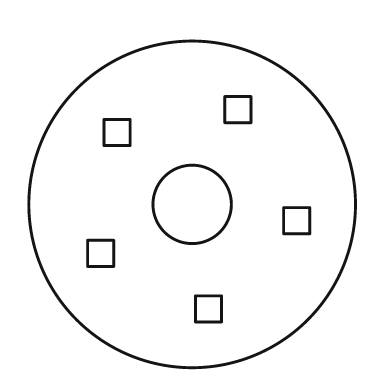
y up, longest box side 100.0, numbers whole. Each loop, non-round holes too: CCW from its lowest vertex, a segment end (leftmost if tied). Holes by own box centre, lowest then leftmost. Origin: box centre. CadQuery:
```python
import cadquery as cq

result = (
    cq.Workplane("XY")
    .moveTo(0.0, 0.0)
    .circle(50.0)
    .moveTo(1.0, -36.0)
    .lineTo(9.0, -36.0)
    .lineTo(9.0, -28.0)
    .lineTo(1.0, -28.0)
    .close()
    .moveTo(-32.0, -19.0)
    .lineTo(-24.0, -19.0)
    .lineTo(-24.0, -11.0)
    .lineTo(-32.0, -11.0)
    .close()
    .moveTo(28.0, -9.0)
    .lineTo(36.0, -9.0)
    .lineTo(36.0, -1.0)
    .lineTo(28.0, -1.0)
    .close()
    .moveTo(0.0, 0.0)
    .circle(12.0)
    .moveTo(-27.0, 18.0)
    .lineTo(-19.0, 18.0)
    .lineTo(-19.0, 26.0)
    .lineTo(-27.0, 26.0)
    .close()
    .moveTo(10.0, 25.0)
    .lineTo(18.0, 25.0)
    .lineTo(18.0, 33.0)
    .lineTo(10.0, 33.0)
    .close()
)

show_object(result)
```